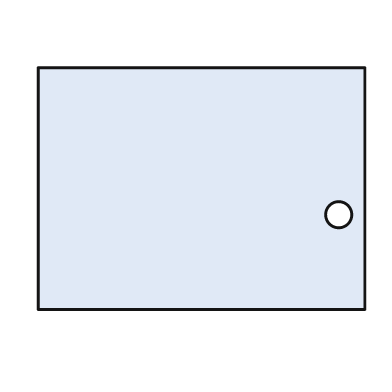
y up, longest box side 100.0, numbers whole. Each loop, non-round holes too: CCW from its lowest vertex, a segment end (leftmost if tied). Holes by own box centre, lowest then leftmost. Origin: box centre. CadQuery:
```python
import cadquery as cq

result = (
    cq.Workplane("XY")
    .moveTo(-50.0, -37.0)
    .lineTo(50.0, -37.0)
    .lineTo(50.0, 37.0)
    .lineTo(-50.0, 37.0)
    .close()
    .moveTo(42.0, -8.0)
    .circle(4.0)
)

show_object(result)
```